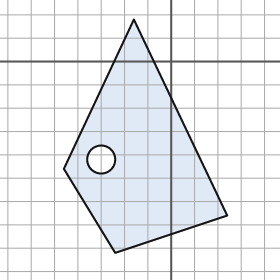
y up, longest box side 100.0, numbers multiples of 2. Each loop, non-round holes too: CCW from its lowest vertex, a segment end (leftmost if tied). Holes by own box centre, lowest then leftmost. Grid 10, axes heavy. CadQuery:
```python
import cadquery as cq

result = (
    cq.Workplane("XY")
    .moveTo(-24.0, -82.0)
    .lineTo(24.0, -66.0)
    .lineTo(-16.0, 18.0)
    .lineTo(-46.0, -46.0)
    .close()
    .moveTo(-30.0, -42.0)
    .circle(6.0)
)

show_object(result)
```